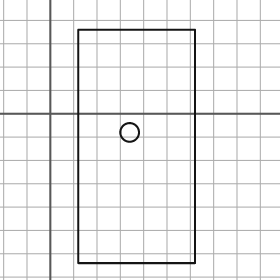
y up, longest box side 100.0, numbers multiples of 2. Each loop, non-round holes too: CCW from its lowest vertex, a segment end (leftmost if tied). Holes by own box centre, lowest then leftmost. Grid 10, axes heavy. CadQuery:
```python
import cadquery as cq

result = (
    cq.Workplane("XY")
    .moveTo(12.0, -64.0)
    .lineTo(62.0, -64.0)
    .lineTo(62.0, 36.0)
    .lineTo(12.0, 36.0)
    .close()
    .moveTo(34.0, -8.0)
    .circle(4.0)
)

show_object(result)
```